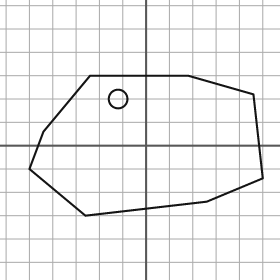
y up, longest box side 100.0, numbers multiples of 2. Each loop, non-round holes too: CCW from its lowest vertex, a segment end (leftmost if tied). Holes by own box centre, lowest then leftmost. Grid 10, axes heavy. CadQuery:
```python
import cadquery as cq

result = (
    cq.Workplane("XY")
    .moveTo(-26.0, -30.0)
    .lineTo(26.0, -24.0)
    .lineTo(50.0, -14.0)
    .lineTo(46.0, 22.0)
    .lineTo(18.0, 30.0)
    .lineTo(-24.0, 30.0)
    .lineTo(-44.0, 6.0)
    .lineTo(-50.0, -10.0)
    .close()
    .moveTo(-12.0, 20.0)
    .circle(4.0)
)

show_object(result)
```